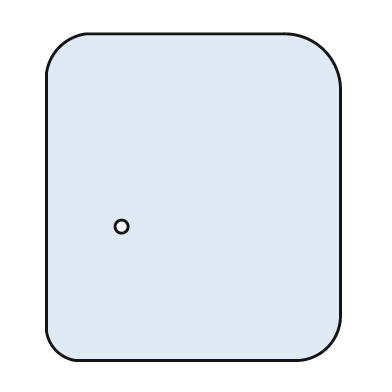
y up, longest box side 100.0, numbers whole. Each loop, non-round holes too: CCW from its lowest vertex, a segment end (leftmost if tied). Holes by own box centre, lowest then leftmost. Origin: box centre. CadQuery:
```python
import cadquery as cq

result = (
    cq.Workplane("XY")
    .moveTo(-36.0, -50.0)
    .lineTo(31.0, -50.0)
    .threePointArc((41.0, -46.0), (45.0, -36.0))
    .lineTo(45.0, 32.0)
    .threePointArc((40.0, 45.0), (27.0, 50.0))
    .lineTo(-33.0, 50.0)
    .threePointArc((-41.0, 46.0), (-45.0, 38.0))
    .lineTo(-45.0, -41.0)
    .threePointArc((-42.0, -47.0), (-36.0, -50.0))
    .close()
    .moveTo(-22.0, -9.0)
    .circle(2.0)
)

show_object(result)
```